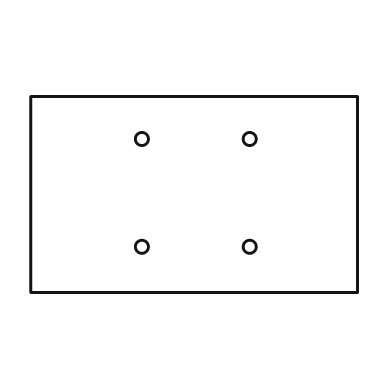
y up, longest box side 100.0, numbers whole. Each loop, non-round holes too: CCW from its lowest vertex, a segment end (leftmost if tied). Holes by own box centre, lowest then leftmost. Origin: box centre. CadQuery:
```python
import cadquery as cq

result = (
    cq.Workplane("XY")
    .moveTo(-50.0, -30.0)
    .lineTo(50.0, -30.0)
    .lineTo(50.0, 30.0)
    .lineTo(-50.0, 30.0)
    .close()
    .moveTo(-16.0, -16.0)
    .circle(2.0)
    .moveTo(17.0, -16.0)
    .circle(2.0)
    .moveTo(-16.0, 17.0)
    .circle(2.0)
    .moveTo(17.0, 17.0)
    .circle(2.0)
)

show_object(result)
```